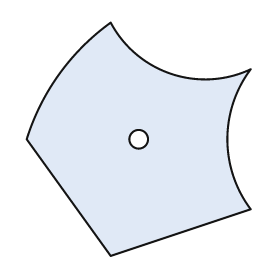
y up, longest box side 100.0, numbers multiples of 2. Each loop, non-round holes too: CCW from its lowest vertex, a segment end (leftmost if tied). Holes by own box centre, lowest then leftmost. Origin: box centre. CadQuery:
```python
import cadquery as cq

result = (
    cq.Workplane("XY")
    .moveTo(-12.0, -50.0)
    .lineTo(48.0, -30.0)
    .threePointArc((38.0, 0.0), (48.0, 30.0))
    .threePointArc((14.0, 28.0), (-12.0, 50.0))
    .threePointArc((-34.0, 28.0), (-48.0, 0.0))
    .close()
    .moveTo(0.0, 0.0)
    .circle(4.0)
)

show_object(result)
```